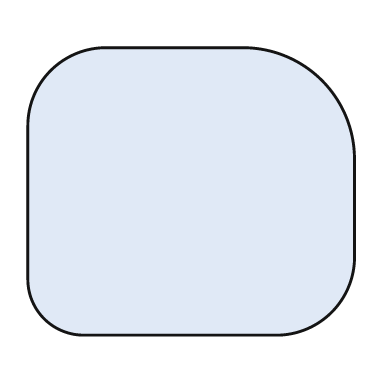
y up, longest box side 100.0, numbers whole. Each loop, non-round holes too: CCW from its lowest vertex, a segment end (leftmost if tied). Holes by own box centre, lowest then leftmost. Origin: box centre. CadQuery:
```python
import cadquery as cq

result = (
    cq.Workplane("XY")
    .moveTo(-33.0, -44.0)
    .lineTo(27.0, -44.0)
    .threePointArc((43.0, -37.0), (50.0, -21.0))
    .lineTo(50.0, 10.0)
    .threePointArc((40.0, 34.0), (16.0, 44.0))
    .lineTo(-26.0, 44.0)
    .threePointArc((-43.0, 37.0), (-50.0, 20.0))
    .lineTo(-50.0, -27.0)
    .threePointArc((-45.0, -39.0), (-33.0, -44.0))
    .close()
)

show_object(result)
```